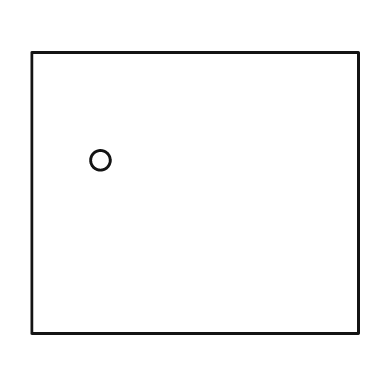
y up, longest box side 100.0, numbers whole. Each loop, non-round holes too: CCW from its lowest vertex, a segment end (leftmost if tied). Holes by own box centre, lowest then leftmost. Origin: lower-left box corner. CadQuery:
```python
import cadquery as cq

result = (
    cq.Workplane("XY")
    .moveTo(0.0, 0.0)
    .lineTo(100.0, 0.0)
    .lineTo(100.0, 86.0)
    .lineTo(0.0, 86.0)
    .close()
    .moveTo(21.0, 53.0)
    .circle(3.0)
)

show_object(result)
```